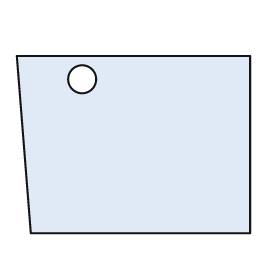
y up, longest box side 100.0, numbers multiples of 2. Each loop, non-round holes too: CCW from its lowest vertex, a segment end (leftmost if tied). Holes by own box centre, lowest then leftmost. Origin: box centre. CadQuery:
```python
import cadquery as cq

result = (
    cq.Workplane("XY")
    .moveTo(-44.0, -38.0)
    .lineTo(50.0, -38.0)
    .lineTo(50.0, 38.0)
    .lineTo(-50.0, 38.0)
    .close()
    .moveTo(-22.0, 28.0)
    .circle(6.0)
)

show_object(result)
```